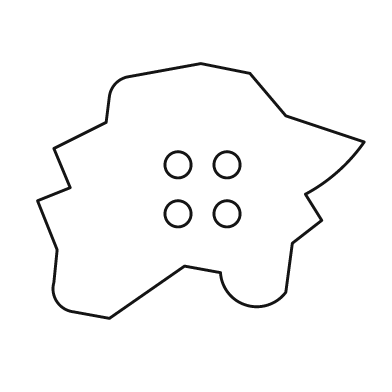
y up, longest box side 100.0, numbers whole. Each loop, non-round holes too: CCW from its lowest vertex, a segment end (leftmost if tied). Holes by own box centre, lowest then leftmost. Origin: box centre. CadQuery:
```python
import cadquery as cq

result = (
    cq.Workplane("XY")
    .moveTo(-28.0, -39.0)
    .lineTo(-5.0, -23.0)
    .lineTo(6.0, -25.0)
    .threePointArc((14.0, -35.0), (26.0, -31.0))
    .lineTo(28.0, -16.0)
    .lineTo(37.0, -9.0)
    .lineTo(32.0, -1.0)
    .threePointArc((42.0, 6.0), (50.0, 15.0))
    .lineTo(26.0, 23.0)
    .lineTo(15.0, 36.0)
    .lineTo(0.0, 39.0)
    .lineTo(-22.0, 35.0)
    .threePointArc((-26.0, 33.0), (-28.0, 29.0))
    .lineTo(-29.0, 21.0)
    .lineTo(-45.0, 13.0)
    .lineTo(-40.0, 1.0)
    .lineTo(-50.0, -3.0)
    .lineTo(-44.0, -18.0)
    .lineTo(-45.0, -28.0)
    .threePointArc((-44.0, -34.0), (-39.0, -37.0))
    .close()
    .moveTo(-7.0, -7.0)
    .circle(4.0)
    .moveTo(8.0, -7.0)
    .circle(4.0)
    .moveTo(-7.0, 8.0)
    .circle(4.0)
    .moveTo(8.0, 8.0)
    .circle(4.0)
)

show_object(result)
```